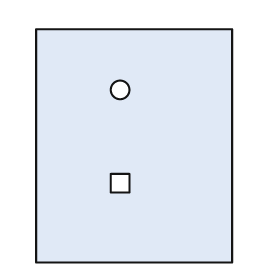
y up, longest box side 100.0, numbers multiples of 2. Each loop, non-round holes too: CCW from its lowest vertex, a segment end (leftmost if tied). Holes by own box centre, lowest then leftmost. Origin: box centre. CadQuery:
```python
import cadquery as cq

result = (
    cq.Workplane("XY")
    .moveTo(-42.0, -50.0)
    .lineTo(42.0, -50.0)
    .lineTo(42.0, 50.0)
    .lineTo(-42.0, 50.0)
    .close()
    .moveTo(-10.0, -20.0)
    .lineTo(-2.0, -20.0)
    .lineTo(-2.0, -12.0)
    .lineTo(-10.0, -12.0)
    .close()
    .moveTo(-6.0, 24.0)
    .circle(4.0)
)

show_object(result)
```